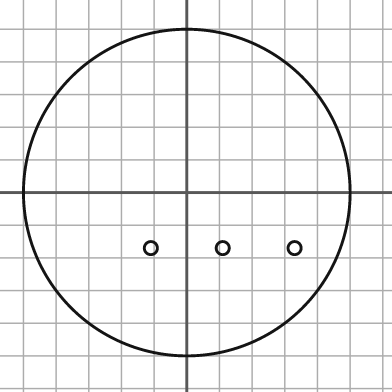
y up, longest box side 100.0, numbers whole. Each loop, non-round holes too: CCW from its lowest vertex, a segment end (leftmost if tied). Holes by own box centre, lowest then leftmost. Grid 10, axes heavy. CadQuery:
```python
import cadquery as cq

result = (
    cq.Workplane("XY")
    .moveTo(0.0, 0.0)
    .circle(50.0)
    .moveTo(-11.0, -17.0)
    .circle(2.0)
    .moveTo(11.0, -17.0)
    .circle(2.0)
    .moveTo(33.0, -17.0)
    .circle(2.0)
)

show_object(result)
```